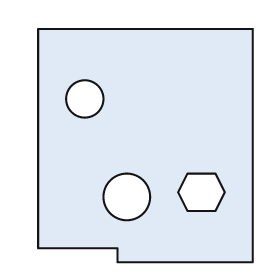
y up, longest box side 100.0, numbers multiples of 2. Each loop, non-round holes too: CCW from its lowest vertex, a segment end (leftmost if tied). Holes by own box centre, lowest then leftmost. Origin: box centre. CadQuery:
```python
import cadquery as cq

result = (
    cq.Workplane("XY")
    .moveTo(-12.0, -50.0)
    .lineTo(46.0, -50.0)
    .lineTo(46.0, 50.0)
    .lineTo(-46.0, 50.0)
    .lineTo(-46.0, -44.0)
    .lineTo(-12.0, -44.0)
    .close()
    .moveTo(-8.0, -22.0)
    .circle(10.0)
    .moveTo(18.0, -28.0)
    .lineTo(30.0, -28.0)
    .lineTo(34.0, -20.0)
    .lineTo(30.0, -12.0)
    .lineTo(18.0, -12.0)
    .lineTo(14.0, -20.0)
    .close()
    .moveTo(-26.0, 20.0)
    .circle(8.0)
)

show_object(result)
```